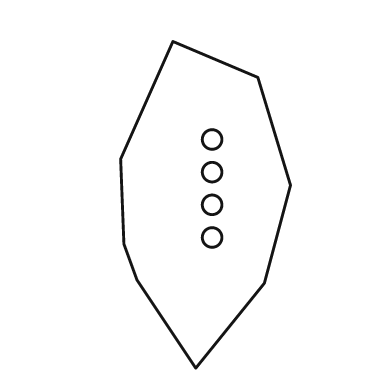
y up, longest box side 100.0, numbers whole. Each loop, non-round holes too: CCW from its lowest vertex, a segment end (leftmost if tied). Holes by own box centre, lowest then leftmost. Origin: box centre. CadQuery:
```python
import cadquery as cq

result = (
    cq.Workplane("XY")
    .moveTo(-3.0, -50.0)
    .lineTo(18.0, -24.0)
    .lineTo(26.0, 6.0)
    .lineTo(16.0, 39.0)
    .lineTo(-10.0, 50.0)
    .lineTo(-26.0, 14.0)
    .lineTo(-25.0, -12.0)
    .lineTo(-21.0, -23.0)
    .close()
    .moveTo(2.0, -10.0)
    .circle(3.0)
    .moveTo(2.0, 0.0)
    .circle(3.0)
    .moveTo(2.0, 10.0)
    .circle(3.0)
    .moveTo(2.0, 20.0)
    .circle(3.0)
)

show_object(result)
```